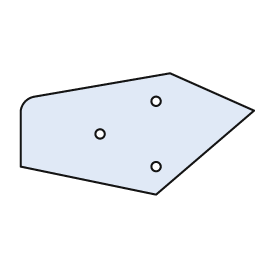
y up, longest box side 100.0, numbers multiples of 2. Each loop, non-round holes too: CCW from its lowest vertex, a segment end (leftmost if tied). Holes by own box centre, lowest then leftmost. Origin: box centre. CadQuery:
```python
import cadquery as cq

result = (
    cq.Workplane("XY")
    .moveTo(8.0, -26.0)
    .lineTo(50.0, 10.0)
    .lineTo(14.0, 26.0)
    .lineTo(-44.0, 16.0)
    .threePointArc((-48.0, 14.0), (-50.0, 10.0))
    .lineTo(-50.0, -14.0)
    .close()
    .moveTo(8.0, -14.0)
    .circle(2.0)
    .moveTo(-16.0, 0.0)
    .circle(2.0)
    .moveTo(8.0, 14.0)
    .circle(2.0)
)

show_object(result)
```